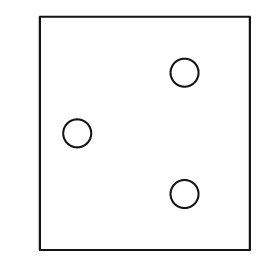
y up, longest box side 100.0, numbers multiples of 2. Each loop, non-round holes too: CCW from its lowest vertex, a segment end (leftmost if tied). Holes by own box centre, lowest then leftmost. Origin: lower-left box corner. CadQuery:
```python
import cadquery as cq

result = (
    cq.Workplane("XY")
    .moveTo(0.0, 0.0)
    .lineTo(90.0, 0.0)
    .lineTo(90.0, 100.0)
    .lineTo(0.0, 100.0)
    .close()
    .moveTo(62.0, 24.0)
    .circle(6.0)
    .moveTo(16.0, 50.0)
    .circle(6.0)
    .moveTo(62.0, 76.0)
    .circle(6.0)
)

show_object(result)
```